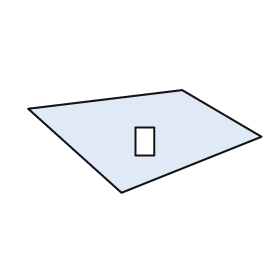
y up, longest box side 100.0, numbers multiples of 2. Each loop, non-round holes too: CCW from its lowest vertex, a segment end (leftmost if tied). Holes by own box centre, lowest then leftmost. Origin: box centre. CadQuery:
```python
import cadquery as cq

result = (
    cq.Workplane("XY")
    .moveTo(-10.0, -22.0)
    .lineTo(50.0, 2.0)
    .lineTo(16.0, 22.0)
    .lineTo(-50.0, 14.0)
    .close()
    .moveTo(-4.0, -6.0)
    .lineTo(4.0, -6.0)
    .lineTo(4.0, 6.0)
    .lineTo(-4.0, 6.0)
    .close()
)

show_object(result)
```